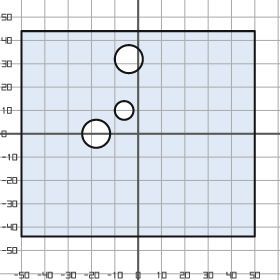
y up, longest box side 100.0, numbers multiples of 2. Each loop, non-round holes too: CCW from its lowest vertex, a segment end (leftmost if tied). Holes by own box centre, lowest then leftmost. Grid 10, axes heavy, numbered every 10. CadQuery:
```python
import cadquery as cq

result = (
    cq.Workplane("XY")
    .moveTo(-50.0, -44.0)
    .lineTo(50.0, -44.0)
    .lineTo(50.0, 44.0)
    .lineTo(-50.0, 44.0)
    .close()
    .moveTo(-18.0, 0.0)
    .circle(6.0)
    .moveTo(-6.0, 10.0)
    .circle(4.0)
    .moveTo(-4.0, 32.0)
    .circle(6.0)
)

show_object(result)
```